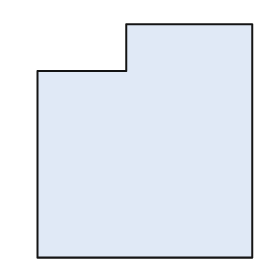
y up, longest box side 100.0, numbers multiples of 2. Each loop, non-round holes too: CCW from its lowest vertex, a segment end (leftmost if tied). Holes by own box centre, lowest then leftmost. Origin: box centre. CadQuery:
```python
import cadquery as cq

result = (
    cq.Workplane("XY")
    .moveTo(-46.0, -50.0)
    .lineTo(46.0, -50.0)
    .lineTo(46.0, 50.0)
    .lineTo(-8.0, 50.0)
    .lineTo(-8.0, 30.0)
    .lineTo(-46.0, 30.0)
    .close()
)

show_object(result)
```